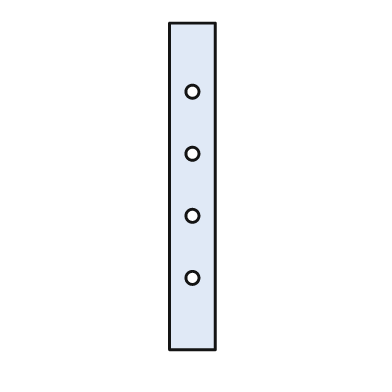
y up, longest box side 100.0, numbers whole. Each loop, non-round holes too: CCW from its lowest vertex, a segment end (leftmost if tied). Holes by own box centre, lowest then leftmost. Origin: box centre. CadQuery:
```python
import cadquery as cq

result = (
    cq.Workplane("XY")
    .moveTo(-7.0, -50.0)
    .lineTo(7.0, -50.0)
    .lineTo(7.0, 50.0)
    .lineTo(-7.0, 50.0)
    .close()
    .moveTo(0.0, -28.0)
    .circle(2.0)
    .moveTo(0.0, -9.0)
    .circle(2.0)
    .moveTo(0.0, 10.0)
    .circle(2.0)
    .moveTo(0.0, 29.0)
    .circle(2.0)
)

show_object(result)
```